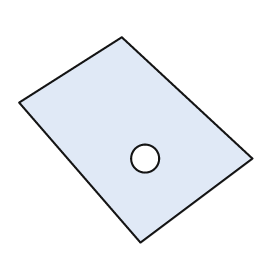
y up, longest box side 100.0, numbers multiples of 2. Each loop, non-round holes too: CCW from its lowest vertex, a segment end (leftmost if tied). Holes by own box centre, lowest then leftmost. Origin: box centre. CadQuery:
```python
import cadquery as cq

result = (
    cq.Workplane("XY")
    .moveTo(2.0, -44.0)
    .lineTo(50.0, -8.0)
    .lineTo(-6.0, 44.0)
    .lineTo(-50.0, 16.0)
    .close()
    .moveTo(4.0, -8.0)
    .circle(6.0)
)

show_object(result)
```